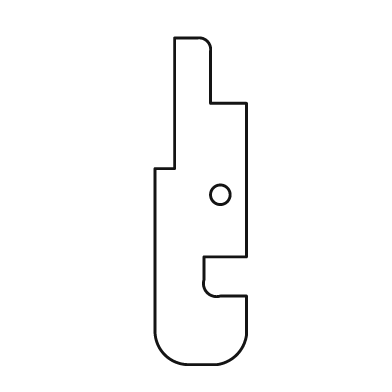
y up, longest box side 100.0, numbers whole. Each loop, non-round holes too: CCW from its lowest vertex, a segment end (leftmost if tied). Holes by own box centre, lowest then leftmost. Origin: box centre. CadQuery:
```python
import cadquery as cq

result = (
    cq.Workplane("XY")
    .moveTo(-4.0, -50.0)
    .lineTo(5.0, -50.0)
    .threePointArc((11.0, -47.0), (14.0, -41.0))
    .lineTo(14.0, -29.0)
    .lineTo(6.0, -29.0)
    .threePointArc((2.0, -28.0), (1.0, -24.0))
    .lineTo(1.0, -17.0)
    .lineTo(14.0, -17.0)
    .lineTo(14.0, 30.0)
    .lineTo(3.0, 30.0)
    .lineTo(3.0, 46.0)
    .threePointArc((2.0, 49.0), (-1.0, 50.0))
    .lineTo(-8.0, 50.0)
    .lineTo(-8.0, 10.0)
    .lineTo(-14.0, 10.0)
    .lineTo(-14.0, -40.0)
    .threePointArc((-11.0, -47.0), (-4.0, -50.0))
    .close()
    .moveTo(6.0, 2.0)
    .circle(3.0)
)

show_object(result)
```